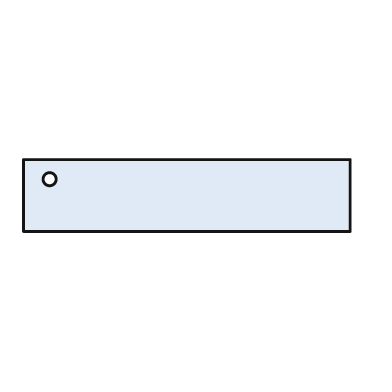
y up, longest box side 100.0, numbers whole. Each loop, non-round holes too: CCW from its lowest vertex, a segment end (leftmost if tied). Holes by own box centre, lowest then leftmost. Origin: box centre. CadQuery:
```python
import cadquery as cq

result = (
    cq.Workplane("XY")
    .moveTo(-50.0, -11.0)
    .lineTo(50.0, -11.0)
    .lineTo(50.0, 11.0)
    .lineTo(-50.0, 11.0)
    .close()
    .moveTo(-42.0, 5.0)
    .circle(2.0)
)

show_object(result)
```